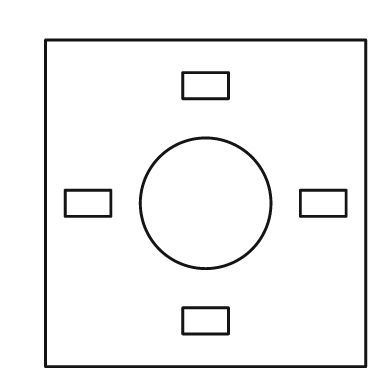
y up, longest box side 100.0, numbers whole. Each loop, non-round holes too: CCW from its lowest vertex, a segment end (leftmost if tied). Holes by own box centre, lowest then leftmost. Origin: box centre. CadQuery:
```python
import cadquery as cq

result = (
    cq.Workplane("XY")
    .moveTo(-49.0, -50.0)
    .lineTo(49.0, -50.0)
    .lineTo(49.0, 50.0)
    .lineTo(-49.0, 50.0)
    .close()
    .moveTo(-7.0, -40.0)
    .lineTo(7.0, -40.0)
    .lineTo(7.0, -32.0)
    .lineTo(-7.0, -32.0)
    .close()
    .moveTo(-43.0, -4.0)
    .lineTo(-29.0, -4.0)
    .lineTo(-29.0, 4.0)
    .lineTo(-43.0, 4.0)
    .close()
    .moveTo(0.0, 0.0)
    .circle(20.0)
    .moveTo(29.0, -4.0)
    .lineTo(43.0, -4.0)
    .lineTo(43.0, 4.0)
    .lineTo(29.0, 4.0)
    .close()
    .moveTo(-7.0, 32.0)
    .lineTo(7.0, 32.0)
    .lineTo(7.0, 40.0)
    .lineTo(-7.0, 40.0)
    .close()
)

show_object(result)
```